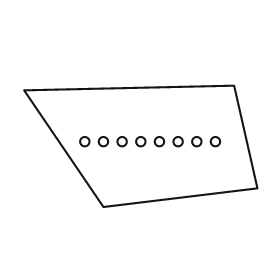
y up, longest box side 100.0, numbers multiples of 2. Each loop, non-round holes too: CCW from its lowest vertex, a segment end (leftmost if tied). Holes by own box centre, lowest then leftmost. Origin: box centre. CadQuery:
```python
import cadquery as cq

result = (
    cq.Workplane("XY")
    .moveTo(-16.0, -26.0)
    .lineTo(50.0, -18.0)
    .lineTo(40.0, 26.0)
    .lineTo(-50.0, 24.0)
    .close()
    .moveTo(-24.0, 2.0)
    .circle(2.0)
    .moveTo(-16.0, 2.0)
    .circle(2.0)
    .moveTo(-8.0, 2.0)
    .circle(2.0)
    .moveTo(0.0, 2.0)
    .circle(2.0)
    .moveTo(8.0, 2.0)
    .circle(2.0)
    .moveTo(16.0, 2.0)
    .circle(2.0)
    .moveTo(24.0, 2.0)
    .circle(2.0)
    .moveTo(32.0, 2.0)
    .circle(2.0)
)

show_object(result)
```